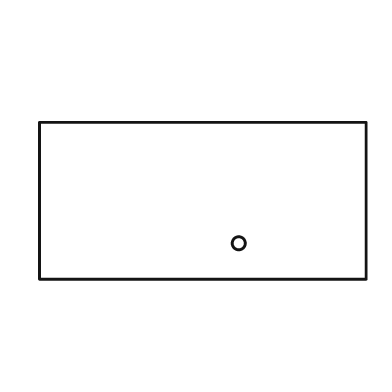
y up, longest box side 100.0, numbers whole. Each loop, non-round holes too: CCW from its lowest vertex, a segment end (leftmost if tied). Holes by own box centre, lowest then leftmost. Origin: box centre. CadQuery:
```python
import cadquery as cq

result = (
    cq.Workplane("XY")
    .moveTo(-50.0, -24.0)
    .lineTo(50.0, -24.0)
    .lineTo(50.0, 24.0)
    .lineTo(-50.0, 24.0)
    .close()
    .moveTo(11.0, -13.0)
    .circle(2.0)
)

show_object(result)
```